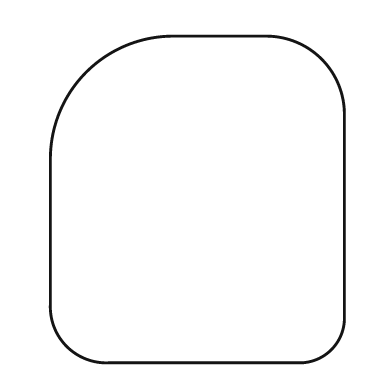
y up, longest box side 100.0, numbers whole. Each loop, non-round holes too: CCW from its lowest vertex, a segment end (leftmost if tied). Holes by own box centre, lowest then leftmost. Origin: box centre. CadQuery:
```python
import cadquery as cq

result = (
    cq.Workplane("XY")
    .moveTo(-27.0, -50.0)
    .lineTo(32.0, -50.0)
    .threePointArc((41.0, -46.0), (45.0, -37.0))
    .lineTo(45.0, 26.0)
    .threePointArc((38.0, 43.0), (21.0, 50.0))
    .lineTo(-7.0, 50.0)
    .threePointArc((-34.0, 39.0), (-45.0, 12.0))
    .lineTo(-45.0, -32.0)
    .threePointArc((-40.0, -45.0), (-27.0, -50.0))
    .close()
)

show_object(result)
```